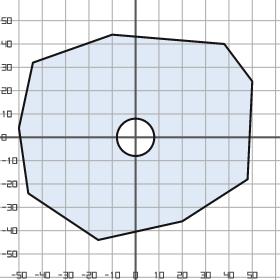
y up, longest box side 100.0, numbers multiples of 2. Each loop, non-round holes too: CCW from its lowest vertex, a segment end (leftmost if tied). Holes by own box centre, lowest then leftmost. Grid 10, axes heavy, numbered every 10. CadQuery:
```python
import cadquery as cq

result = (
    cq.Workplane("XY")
    .moveTo(-16.0, -44.0)
    .lineTo(20.0, -36.0)
    .lineTo(48.0, -18.0)
    .lineTo(50.0, 24.0)
    .lineTo(38.0, 40.0)
    .lineTo(-10.0, 44.0)
    .lineTo(-44.0, 32.0)
    .lineTo(-50.0, 4.0)
    .lineTo(-46.0, -24.0)
    .close()
    .moveTo(0.0, 0.0)
    .circle(8.0)
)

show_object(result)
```